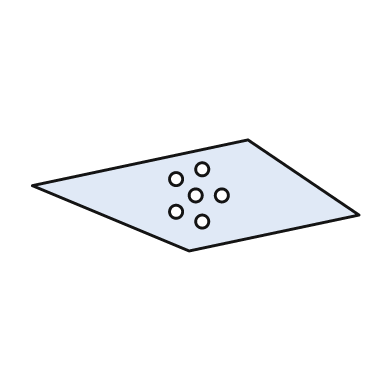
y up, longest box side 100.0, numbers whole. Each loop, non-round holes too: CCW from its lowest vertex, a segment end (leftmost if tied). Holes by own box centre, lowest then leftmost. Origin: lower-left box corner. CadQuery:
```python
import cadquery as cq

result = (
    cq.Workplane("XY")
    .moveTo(48.0, 0.0)
    .lineTo(100.0, 11.0)
    .lineTo(66.0, 34.0)
    .lineTo(0.0, 20.0)
    .close()
    .moveTo(52.0, 9.0)
    .circle(2.0)
    .moveTo(44.0, 12.0)
    .circle(2.0)
    .moveTo(50.0, 17.0)
    .circle(2.0)
    .moveTo(58.0, 17.0)
    .circle(2.0)
    .moveTo(44.0, 22.0)
    .circle(2.0)
    .moveTo(52.0, 25.0)
    .circle(2.0)
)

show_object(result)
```